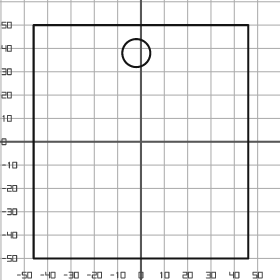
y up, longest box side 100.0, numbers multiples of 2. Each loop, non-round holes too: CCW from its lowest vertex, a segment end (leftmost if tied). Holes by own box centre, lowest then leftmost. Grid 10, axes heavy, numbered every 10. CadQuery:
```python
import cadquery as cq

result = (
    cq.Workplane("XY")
    .moveTo(-46.0, -50.0)
    .lineTo(46.0, -50.0)
    .lineTo(46.0, 50.0)
    .lineTo(-46.0, 50.0)
    .close()
    .moveTo(-2.0, 38.0)
    .circle(6.0)
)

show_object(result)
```